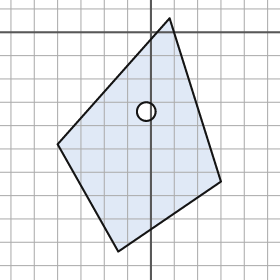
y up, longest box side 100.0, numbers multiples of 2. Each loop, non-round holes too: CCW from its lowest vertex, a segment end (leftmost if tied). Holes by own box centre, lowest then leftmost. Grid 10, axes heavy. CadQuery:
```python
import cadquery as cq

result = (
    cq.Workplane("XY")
    .moveTo(-14.0, -94.0)
    .lineTo(30.0, -64.0)
    .lineTo(8.0, 6.0)
    .lineTo(-40.0, -48.0)
    .close()
    .moveTo(-2.0, -34.0)
    .circle(4.0)
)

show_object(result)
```